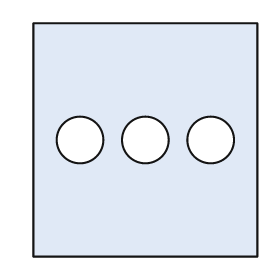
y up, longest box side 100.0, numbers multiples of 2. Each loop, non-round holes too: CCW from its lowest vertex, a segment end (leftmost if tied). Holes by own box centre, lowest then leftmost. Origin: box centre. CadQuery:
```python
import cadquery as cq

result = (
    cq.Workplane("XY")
    .moveTo(-48.0, -50.0)
    .lineTo(48.0, -50.0)
    .lineTo(48.0, 50.0)
    .lineTo(-48.0, 50.0)
    .close()
    .moveTo(-28.0, 0.0)
    .circle(10.0)
    .moveTo(0.0, 0.0)
    .circle(10.0)
    .moveTo(28.0, 0.0)
    .circle(10.0)
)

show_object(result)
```